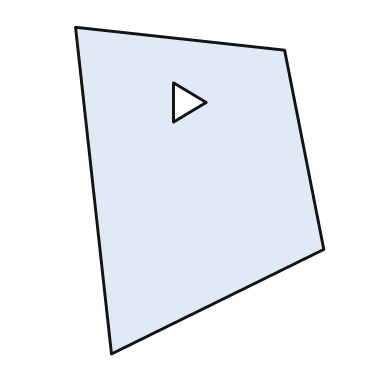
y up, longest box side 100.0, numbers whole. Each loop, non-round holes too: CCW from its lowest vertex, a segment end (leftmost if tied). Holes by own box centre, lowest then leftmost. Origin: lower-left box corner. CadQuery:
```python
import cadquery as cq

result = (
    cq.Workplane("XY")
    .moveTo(11.0, 0.0)
    .lineTo(76.0, 32.0)
    .lineTo(64.0, 93.0)
    .lineTo(0.0, 100.0)
    .close()
    .moveTo(30.0, 71.0)
    .lineTo(40.0, 77.0)
    .lineTo(30.0, 83.0)
    .close()
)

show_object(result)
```